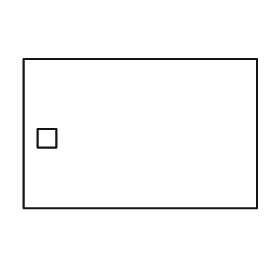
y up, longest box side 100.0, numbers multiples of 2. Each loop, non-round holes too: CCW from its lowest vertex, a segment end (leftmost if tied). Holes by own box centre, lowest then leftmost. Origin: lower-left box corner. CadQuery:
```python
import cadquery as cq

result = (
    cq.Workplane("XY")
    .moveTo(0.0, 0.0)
    .lineTo(100.0, 0.0)
    .lineTo(100.0, 64.0)
    .lineTo(0.0, 64.0)
    .close()
    .moveTo(6.0, 26.0)
    .lineTo(14.0, 26.0)
    .lineTo(14.0, 34.0)
    .lineTo(6.0, 34.0)
    .close()
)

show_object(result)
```